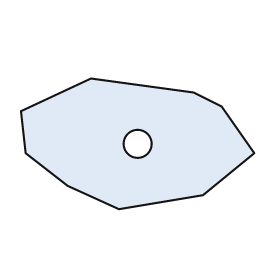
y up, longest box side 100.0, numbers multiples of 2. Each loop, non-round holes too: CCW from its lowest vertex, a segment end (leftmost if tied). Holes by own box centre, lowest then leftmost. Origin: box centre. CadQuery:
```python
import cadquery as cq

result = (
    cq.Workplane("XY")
    .moveTo(-8.0, -28.0)
    .lineTo(28.0, -22.0)
    .lineTo(50.0, -4.0)
    .lineTo(36.0, 16.0)
    .lineTo(24.0, 22.0)
    .lineTo(-20.0, 28.0)
    .lineTo(-50.0, 14.0)
    .lineTo(-48.0, -4.0)
    .lineTo(-30.0, -18.0)
    .close()
    .moveTo(0.0, 0.0)
    .circle(6.0)
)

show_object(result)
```